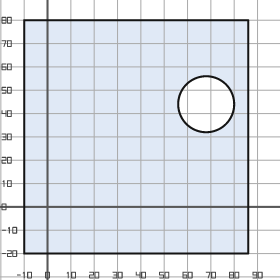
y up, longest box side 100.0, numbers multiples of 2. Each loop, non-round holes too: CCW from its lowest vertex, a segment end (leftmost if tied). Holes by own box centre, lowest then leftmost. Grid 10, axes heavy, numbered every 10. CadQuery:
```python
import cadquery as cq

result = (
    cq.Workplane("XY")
    .moveTo(-10.0, -20.0)
    .lineTo(86.0, -20.0)
    .lineTo(86.0, 80.0)
    .lineTo(-10.0, 80.0)
    .close()
    .moveTo(68.0, 44.0)
    .circle(12.0)
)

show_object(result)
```